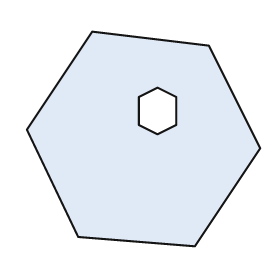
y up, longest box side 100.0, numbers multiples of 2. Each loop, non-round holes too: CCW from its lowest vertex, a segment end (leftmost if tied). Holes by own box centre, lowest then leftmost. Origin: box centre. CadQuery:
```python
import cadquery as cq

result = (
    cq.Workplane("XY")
    .moveTo(22.0, -46.0)
    .lineTo(50.0, -4.0)
    .lineTo(28.0, 40.0)
    .lineTo(-22.0, 46.0)
    .lineTo(-50.0, 4.0)
    .lineTo(-28.0, -42.0)
    .close()
    .moveTo(6.0, 2.0)
    .lineTo(14.0, 6.0)
    .lineTo(14.0, 18.0)
    .lineTo(6.0, 22.0)
    .lineTo(-2.0, 18.0)
    .lineTo(-2.0, 6.0)
    .close()
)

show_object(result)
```